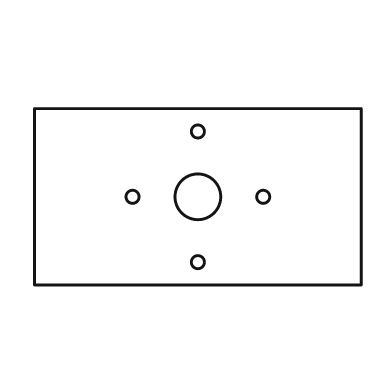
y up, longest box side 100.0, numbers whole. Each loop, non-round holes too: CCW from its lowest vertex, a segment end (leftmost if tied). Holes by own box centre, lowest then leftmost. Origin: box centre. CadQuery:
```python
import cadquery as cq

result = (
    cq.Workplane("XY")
    .moveTo(-50.0, -27.0)
    .lineTo(50.0, -27.0)
    .lineTo(50.0, 27.0)
    .lineTo(-50.0, 27.0)
    .close()
    .moveTo(0.0, -20.0)
    .circle(2.0)
    .moveTo(-20.0, 0.0)
    .circle(2.0)
    .moveTo(0.0, 0.0)
    .circle(7.0)
    .moveTo(20.0, 0.0)
    .circle(2.0)
    .moveTo(0.0, 20.0)
    .circle(2.0)
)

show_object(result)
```